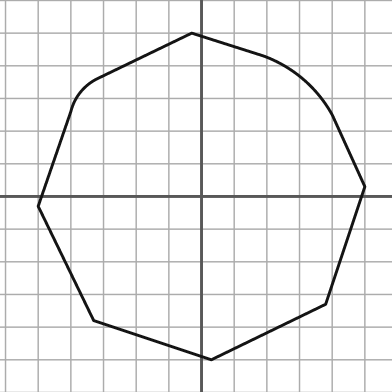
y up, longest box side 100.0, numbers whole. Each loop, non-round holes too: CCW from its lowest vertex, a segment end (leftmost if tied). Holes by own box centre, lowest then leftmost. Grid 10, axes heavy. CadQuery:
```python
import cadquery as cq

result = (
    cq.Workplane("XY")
    .moveTo(3.0, -50.0)
    .lineTo(38.0, -33.0)
    .lineTo(50.0, 3.0)
    .lineTo(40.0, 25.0)
    .threePointArc((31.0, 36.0), (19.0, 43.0))
    .lineTo(-3.0, 50.0)
    .lineTo(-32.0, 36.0)
    .threePointArc((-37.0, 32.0), (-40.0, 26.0))
    .lineTo(-50.0, -3.0)
    .lineTo(-33.0, -38.0)
    .close()
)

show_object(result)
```